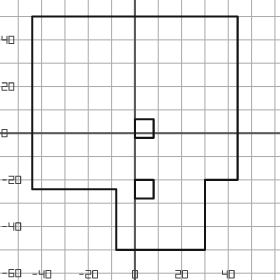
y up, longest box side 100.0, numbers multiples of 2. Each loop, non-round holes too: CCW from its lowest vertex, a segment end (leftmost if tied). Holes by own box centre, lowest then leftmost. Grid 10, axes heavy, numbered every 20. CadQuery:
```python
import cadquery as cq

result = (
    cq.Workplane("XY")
    .moveTo(-8.0, -50.0)
    .lineTo(30.0, -50.0)
    .lineTo(30.0, -20.0)
    .lineTo(44.0, -20.0)
    .lineTo(44.0, 50.0)
    .lineTo(-44.0, 50.0)
    .lineTo(-44.0, -24.0)
    .lineTo(-8.0, -24.0)
    .close()
    .moveTo(0.0, -28.0)
    .lineTo(8.0, -28.0)
    .lineTo(8.0, -20.0)
    .lineTo(0.0, -20.0)
    .close()
    .moveTo(0.0, -2.0)
    .lineTo(8.0, -2.0)
    .lineTo(8.0, 6.0)
    .lineTo(0.0, 6.0)
    .close()
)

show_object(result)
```